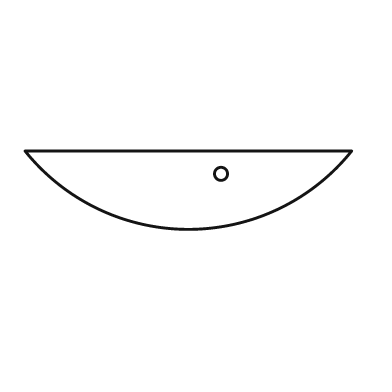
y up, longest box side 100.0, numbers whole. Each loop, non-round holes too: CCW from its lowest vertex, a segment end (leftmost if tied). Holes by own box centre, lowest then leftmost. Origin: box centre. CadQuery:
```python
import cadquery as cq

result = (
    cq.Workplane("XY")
    .moveTo(-50.0, 12.0)
    .threePointArc((0.0, -12.0), (50.0, 12.0))
    .close()
    .moveTo(10.0, 5.0)
    .circle(2.0)
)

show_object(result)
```